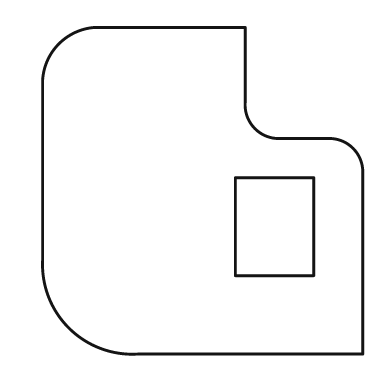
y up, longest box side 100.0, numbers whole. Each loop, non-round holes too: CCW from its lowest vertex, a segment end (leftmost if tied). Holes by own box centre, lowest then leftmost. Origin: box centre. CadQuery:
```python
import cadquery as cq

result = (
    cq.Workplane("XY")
    .moveTo(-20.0, -50.0)
    .lineTo(49.0, -50.0)
    .lineTo(49.0, 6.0)
    .threePointArc((46.0, 13.0), (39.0, 16.0))
    .lineTo(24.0, 16.0)
    .threePointArc((16.0, 19.0), (13.0, 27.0))
    .lineTo(13.0, 50.0)
    .lineTo(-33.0, 50.0)
    .threePointArc((-44.0, 45.0), (-49.0, 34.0))
    .lineTo(-49.0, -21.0)
    .threePointArc((-41.0, -42.0), (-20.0, -50.0))
    .close()
    .moveTo(10.0, -26.0)
    .lineTo(34.0, -26.0)
    .lineTo(34.0, 4.0)
    .lineTo(10.0, 4.0)
    .close()
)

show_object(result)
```